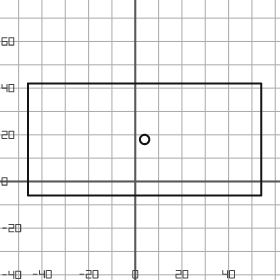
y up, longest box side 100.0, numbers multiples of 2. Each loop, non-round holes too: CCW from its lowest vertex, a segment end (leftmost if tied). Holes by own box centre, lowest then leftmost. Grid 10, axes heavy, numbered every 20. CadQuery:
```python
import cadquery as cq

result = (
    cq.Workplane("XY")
    .moveTo(-46.0, -6.0)
    .lineTo(54.0, -6.0)
    .lineTo(54.0, 42.0)
    .lineTo(-46.0, 42.0)
    .close()
    .moveTo(4.0, 18.0)
    .circle(2.0)
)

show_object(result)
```